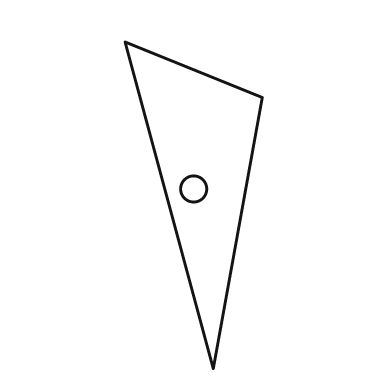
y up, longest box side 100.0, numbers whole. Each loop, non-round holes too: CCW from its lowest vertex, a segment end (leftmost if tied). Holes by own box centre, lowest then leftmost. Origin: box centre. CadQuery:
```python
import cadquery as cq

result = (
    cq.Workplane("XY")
    .moveTo(6.0, -50.0)
    .lineTo(21.0, 33.0)
    .lineTo(-21.0, 50.0)
    .close()
    .moveTo(0.0, 5.0)
    .circle(4.0)
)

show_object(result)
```